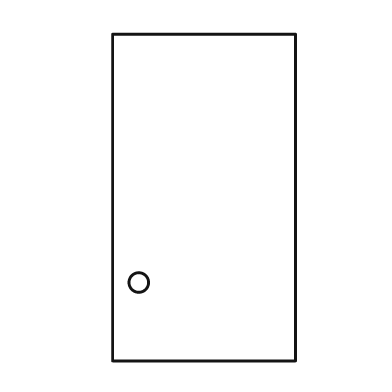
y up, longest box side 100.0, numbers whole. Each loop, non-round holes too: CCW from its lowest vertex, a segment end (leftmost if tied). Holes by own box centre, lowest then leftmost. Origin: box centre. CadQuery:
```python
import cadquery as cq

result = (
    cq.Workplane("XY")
    .moveTo(-28.0, -50.0)
    .lineTo(28.0, -50.0)
    .lineTo(28.0, 50.0)
    .lineTo(-28.0, 50.0)
    .close()
    .moveTo(-20.0, -26.0)
    .circle(3.0)
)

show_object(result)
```